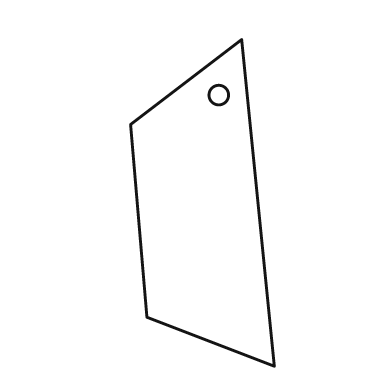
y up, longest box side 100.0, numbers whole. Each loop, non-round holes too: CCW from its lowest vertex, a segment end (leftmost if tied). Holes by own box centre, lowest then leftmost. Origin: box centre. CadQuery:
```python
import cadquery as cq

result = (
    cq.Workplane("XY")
    .moveTo(22.0, -50.0)
    .lineTo(12.0, 50.0)
    .lineTo(-22.0, 24.0)
    .lineTo(-17.0, -35.0)
    .close()
    .moveTo(5.0, 33.0)
    .circle(3.0)
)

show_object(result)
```